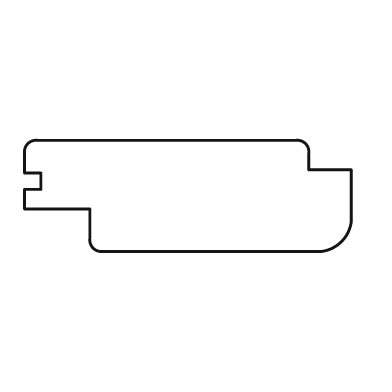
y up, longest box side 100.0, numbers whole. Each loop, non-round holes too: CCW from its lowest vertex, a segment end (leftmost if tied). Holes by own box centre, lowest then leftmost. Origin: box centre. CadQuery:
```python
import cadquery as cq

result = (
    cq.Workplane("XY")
    .moveTo(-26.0, -17.0)
    .lineTo(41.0, -17.0)
    .threePointArc((47.0, -14.0), (50.0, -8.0))
    .lineTo(50.0, 8.0)
    .lineTo(37.0, 8.0)
    .lineTo(37.0, 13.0)
    .threePointArc((36.0, 16.0), (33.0, 17.0))
    .lineTo(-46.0, 17.0)
    .threePointArc((-49.0, 16.0), (-50.0, 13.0))
    .lineTo(-50.0, 7.0)
    .lineTo(-45.0, 7.0)
    .lineTo(-45.0, 2.0)
    .lineTo(-50.0, 2.0)
    .lineTo(-50.0, -4.0)
    .lineTo(-30.0, -4.0)
    .lineTo(-30.0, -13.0)
    .threePointArc((-29.0, -16.0), (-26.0, -17.0))
    .close()
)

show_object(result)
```